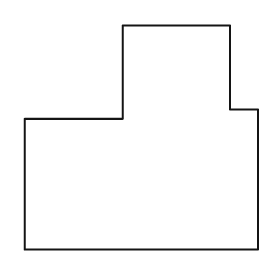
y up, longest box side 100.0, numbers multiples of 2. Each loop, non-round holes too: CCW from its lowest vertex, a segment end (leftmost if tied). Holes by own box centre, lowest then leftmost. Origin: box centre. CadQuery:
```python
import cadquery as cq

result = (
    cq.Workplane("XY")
    .moveTo(-50.0, -48.0)
    .lineTo(50.0, -48.0)
    .lineTo(50.0, 12.0)
    .lineTo(38.0, 12.0)
    .lineTo(38.0, 48.0)
    .lineTo(-8.0, 48.0)
    .lineTo(-8.0, 8.0)
    .lineTo(-50.0, 8.0)
    .close()
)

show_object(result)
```